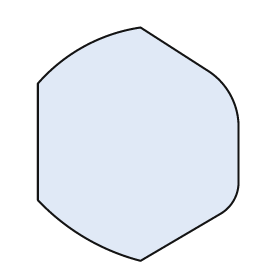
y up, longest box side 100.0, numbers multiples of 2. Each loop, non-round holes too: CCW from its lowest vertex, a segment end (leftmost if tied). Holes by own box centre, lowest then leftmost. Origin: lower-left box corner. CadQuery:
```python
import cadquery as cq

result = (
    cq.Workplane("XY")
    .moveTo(44.0, 0.0)
    .lineTo(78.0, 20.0)
    .threePointArc((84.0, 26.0), (86.0, 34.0))
    .lineTo(86.0, 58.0)
    .threePointArc((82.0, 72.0), (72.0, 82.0))
    .lineTo(44.0, 100.0)
    .threePointArc((20.0, 92.0), (0.0, 76.0))
    .lineTo(0.0, 26.0)
    .threePointArc((20.0, 10.0), (44.0, 0.0))
    .close()
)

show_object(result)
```